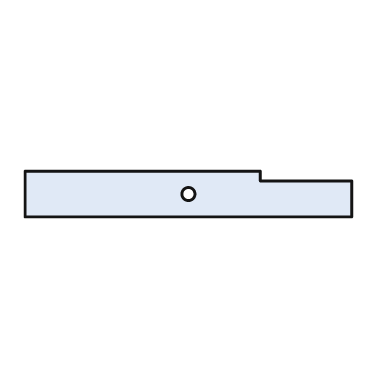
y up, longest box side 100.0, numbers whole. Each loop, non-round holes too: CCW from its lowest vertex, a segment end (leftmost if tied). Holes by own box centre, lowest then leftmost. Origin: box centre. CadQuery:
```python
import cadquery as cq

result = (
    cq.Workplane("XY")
    .moveTo(-50.0, -7.0)
    .lineTo(50.0, -7.0)
    .lineTo(50.0, 4.0)
    .lineTo(22.0, 4.0)
    .lineTo(22.0, 7.0)
    .lineTo(-50.0, 7.0)
    .close()
    .moveTo(0.0, 0.0)
    .circle(2.0)
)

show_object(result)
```